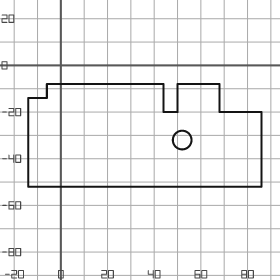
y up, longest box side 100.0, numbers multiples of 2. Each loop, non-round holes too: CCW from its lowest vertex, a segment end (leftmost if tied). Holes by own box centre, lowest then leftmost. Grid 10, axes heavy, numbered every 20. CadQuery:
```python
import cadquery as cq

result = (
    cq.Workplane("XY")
    .moveTo(-14.0, -52.0)
    .lineTo(86.0, -52.0)
    .lineTo(86.0, -20.0)
    .lineTo(68.0, -20.0)
    .lineTo(68.0, -8.0)
    .lineTo(50.0, -8.0)
    .lineTo(50.0, -20.0)
    .lineTo(44.0, -20.0)
    .lineTo(44.0, -8.0)
    .lineTo(-6.0, -8.0)
    .lineTo(-6.0, -14.0)
    .lineTo(-14.0, -14.0)
    .close()
    .moveTo(52.0, -32.0)
    .circle(4.0)
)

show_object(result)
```